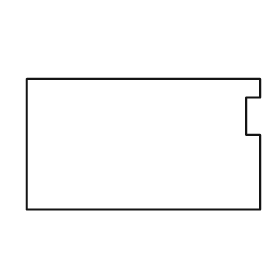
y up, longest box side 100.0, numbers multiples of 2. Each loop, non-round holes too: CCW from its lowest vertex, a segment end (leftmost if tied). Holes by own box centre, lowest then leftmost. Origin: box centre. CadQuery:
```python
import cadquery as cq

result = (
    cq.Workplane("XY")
    .moveTo(-50.0, -28.0)
    .lineTo(50.0, -28.0)
    .lineTo(50.0, 4.0)
    .lineTo(44.0, 4.0)
    .lineTo(44.0, 20.0)
    .lineTo(50.0, 20.0)
    .lineTo(50.0, 28.0)
    .lineTo(-50.0, 28.0)
    .close()
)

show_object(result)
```